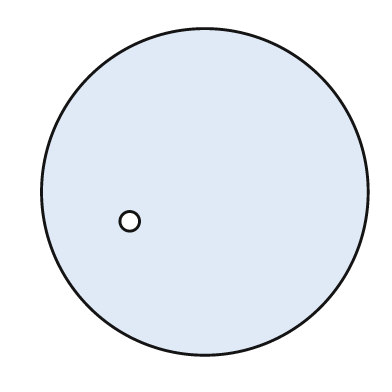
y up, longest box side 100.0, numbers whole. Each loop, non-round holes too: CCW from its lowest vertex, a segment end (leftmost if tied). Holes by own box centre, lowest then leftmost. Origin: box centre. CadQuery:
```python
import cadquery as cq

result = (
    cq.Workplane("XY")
    .moveTo(0.0, 0.0)
    .circle(50.0)
    .moveTo(-23.0, -9.0)
    .circle(3.0)
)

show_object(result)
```